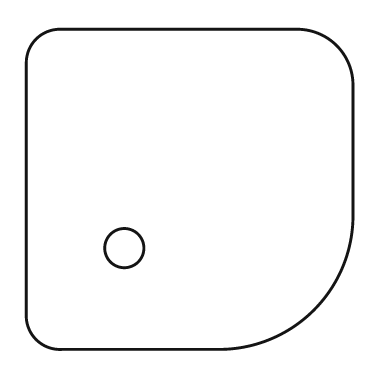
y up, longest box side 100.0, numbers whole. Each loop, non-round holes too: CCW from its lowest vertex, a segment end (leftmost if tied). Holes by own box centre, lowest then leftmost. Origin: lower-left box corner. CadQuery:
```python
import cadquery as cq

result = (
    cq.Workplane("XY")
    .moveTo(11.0, 0.0)
    .lineTo(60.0, 0.0)
    .threePointArc((88.0, 12.0), (100.0, 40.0))
    .lineTo(100.0, 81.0)
    .threePointArc((95.0, 93.0), (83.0, 98.0))
    .lineTo(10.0, 98.0)
    .threePointArc((3.0, 95.0), (0.0, 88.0))
    .lineTo(0.0, 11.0)
    .threePointArc((3.0, 3.0), (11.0, 0.0))
    .close()
    .moveTo(30.0, 31.0)
    .circle(6.0)
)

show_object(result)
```